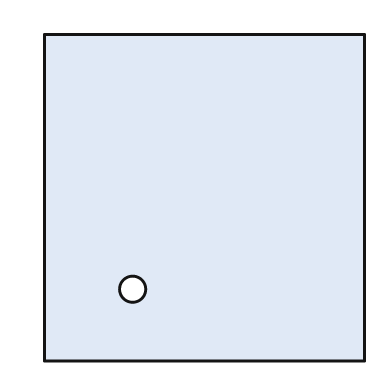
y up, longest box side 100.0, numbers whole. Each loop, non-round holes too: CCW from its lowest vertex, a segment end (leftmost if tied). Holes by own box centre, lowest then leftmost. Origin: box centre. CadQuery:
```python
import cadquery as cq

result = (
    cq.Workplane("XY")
    .moveTo(-49.0, -50.0)
    .lineTo(49.0, -50.0)
    .lineTo(49.0, 50.0)
    .lineTo(-49.0, 50.0)
    .close()
    .moveTo(-22.0, -28.0)
    .circle(4.0)
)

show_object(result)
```